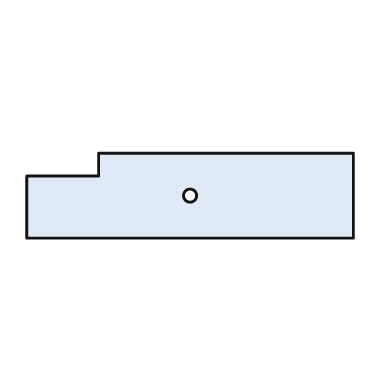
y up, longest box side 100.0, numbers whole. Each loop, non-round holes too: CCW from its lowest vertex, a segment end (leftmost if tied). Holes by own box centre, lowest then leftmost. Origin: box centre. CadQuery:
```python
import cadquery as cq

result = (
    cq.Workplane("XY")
    .moveTo(-50.0, -13.0)
    .lineTo(50.0, -13.0)
    .lineTo(50.0, 13.0)
    .lineTo(-28.0, 13.0)
    .lineTo(-28.0, 6.0)
    .lineTo(-50.0, 6.0)
    .close()
    .moveTo(0.0, 0.0)
    .circle(2.0)
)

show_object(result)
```